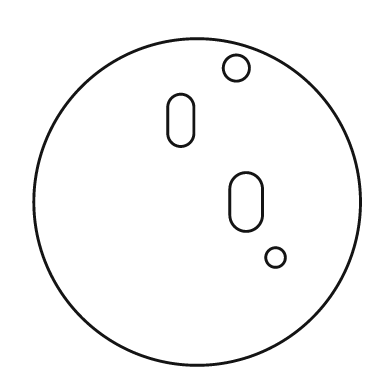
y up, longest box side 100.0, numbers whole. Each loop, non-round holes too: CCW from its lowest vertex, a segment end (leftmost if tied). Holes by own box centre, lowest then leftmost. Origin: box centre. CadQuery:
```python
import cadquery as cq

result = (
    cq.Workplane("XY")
    .moveTo(0.0, 0.0)
    .circle(50.0)
    .moveTo(24.0, -17.0)
    .circle(3.0)
    .moveTo(10.0, -4.0)
    .threePointArc((15.0, -9.0), (20.0, -4.0))
    .lineTo(20.0, 4.0)
    .threePointArc((15.0, 9.0), (10.0, 4.0))
    .close()
    .moveTo(-9.0, 21.0)
    .threePointArc((-5.0, 17.0), (-1.0, 21.0))
    .lineTo(-1.0, 29.0)
    .threePointArc((-5.0, 33.0), (-9.0, 29.0))
    .close()
    .moveTo(12.0, 41.0)
    .circle(4.0)
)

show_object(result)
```